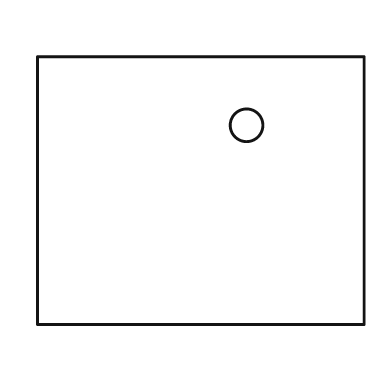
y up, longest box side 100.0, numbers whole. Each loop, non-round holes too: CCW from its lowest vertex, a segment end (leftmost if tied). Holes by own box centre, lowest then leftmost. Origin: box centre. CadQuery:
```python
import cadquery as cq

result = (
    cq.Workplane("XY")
    .moveTo(-50.0, -41.0)
    .lineTo(50.0, -41.0)
    .lineTo(50.0, 41.0)
    .lineTo(-50.0, 41.0)
    .close()
    .moveTo(14.0, 20.0)
    .circle(5.0)
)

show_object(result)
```